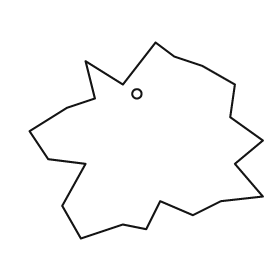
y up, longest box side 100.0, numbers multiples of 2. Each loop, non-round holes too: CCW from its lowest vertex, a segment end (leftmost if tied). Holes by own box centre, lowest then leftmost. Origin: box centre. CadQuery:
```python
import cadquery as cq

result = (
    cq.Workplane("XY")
    .moveTo(-28.0, -42.0)
    .lineTo(-10.0, -36.0)
    .lineTo(0.0, -38.0)
    .lineTo(6.0, -26.0)
    .lineTo(20.0, -32.0)
    .lineTo(32.0, -26.0)
    .lineTo(50.0, -24.0)
    .lineTo(38.0, -10.0)
    .lineTo(50.0, 0.0)
    .lineTo(36.0, 10.0)
    .lineTo(38.0, 24.0)
    .lineTo(24.0, 32.0)
    .lineTo(12.0, 36.0)
    .lineTo(4.0, 42.0)
    .lineTo(-10.0, 24.0)
    .lineTo(-26.0, 34.0)
    .lineTo(-22.0, 18.0)
    .lineTo(-34.0, 14.0)
    .lineTo(-50.0, 4.0)
    .lineTo(-42.0, -8.0)
    .lineTo(-26.0, -10.0)
    .lineTo(-36.0, -28.0)
    .close()
    .moveTo(-4.0, 20.0)
    .circle(2.0)
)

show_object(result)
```